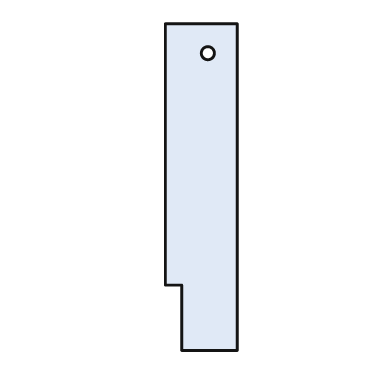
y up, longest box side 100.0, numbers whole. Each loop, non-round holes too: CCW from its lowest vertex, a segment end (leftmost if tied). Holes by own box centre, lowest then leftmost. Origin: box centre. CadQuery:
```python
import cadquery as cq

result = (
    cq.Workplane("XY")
    .moveTo(-6.0, -50.0)
    .lineTo(11.0, -50.0)
    .lineTo(11.0, 50.0)
    .lineTo(-11.0, 50.0)
    .lineTo(-11.0, -30.0)
    .lineTo(-6.0, -30.0)
    .close()
    .moveTo(2.0, 41.0)
    .circle(2.0)
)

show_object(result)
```